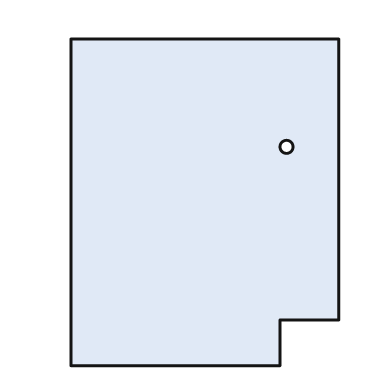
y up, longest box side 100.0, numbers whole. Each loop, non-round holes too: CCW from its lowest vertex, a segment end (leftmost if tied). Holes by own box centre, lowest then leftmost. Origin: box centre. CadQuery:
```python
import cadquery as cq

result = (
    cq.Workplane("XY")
    .moveTo(-41.0, -50.0)
    .lineTo(23.0, -50.0)
    .lineTo(23.0, -36.0)
    .lineTo(41.0, -36.0)
    .lineTo(41.0, 50.0)
    .lineTo(-41.0, 50.0)
    .close()
    .moveTo(25.0, 17.0)
    .circle(2.0)
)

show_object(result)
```